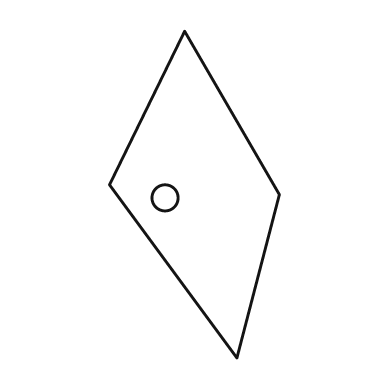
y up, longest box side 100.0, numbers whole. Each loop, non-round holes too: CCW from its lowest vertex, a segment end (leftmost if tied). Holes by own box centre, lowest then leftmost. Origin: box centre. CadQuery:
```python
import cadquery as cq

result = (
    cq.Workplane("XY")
    .moveTo(13.0, -50.0)
    .lineTo(26.0, 0.0)
    .lineTo(-3.0, 50.0)
    .lineTo(-26.0, 3.0)
    .close()
    .moveTo(-9.0, -1.0)
    .circle(4.0)
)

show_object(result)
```